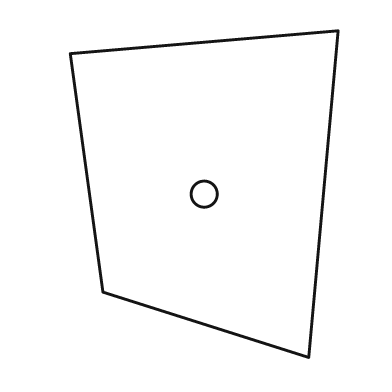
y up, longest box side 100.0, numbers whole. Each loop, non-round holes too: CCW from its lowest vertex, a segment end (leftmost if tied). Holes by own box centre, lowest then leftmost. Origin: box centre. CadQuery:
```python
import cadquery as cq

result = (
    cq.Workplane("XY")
    .moveTo(32.0, -50.0)
    .lineTo(41.0, 50.0)
    .lineTo(-41.0, 43.0)
    .lineTo(-31.0, -30.0)
    .close()
    .moveTo(0.0, 0.0)
    .circle(4.0)
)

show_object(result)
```